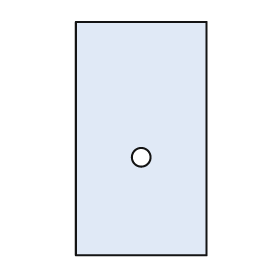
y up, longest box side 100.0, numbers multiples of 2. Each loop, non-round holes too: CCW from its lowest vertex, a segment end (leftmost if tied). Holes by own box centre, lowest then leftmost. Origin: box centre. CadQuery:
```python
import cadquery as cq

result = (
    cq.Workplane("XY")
    .moveTo(-28.0, -50.0)
    .lineTo(28.0, -50.0)
    .lineTo(28.0, 50.0)
    .lineTo(-28.0, 50.0)
    .close()
    .moveTo(0.0, -8.0)
    .circle(4.0)
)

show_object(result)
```